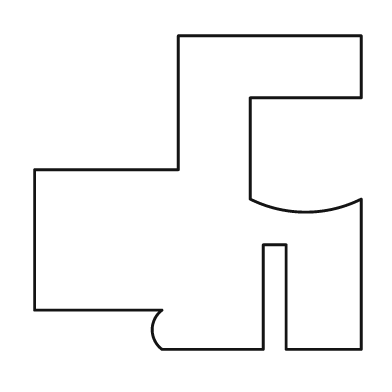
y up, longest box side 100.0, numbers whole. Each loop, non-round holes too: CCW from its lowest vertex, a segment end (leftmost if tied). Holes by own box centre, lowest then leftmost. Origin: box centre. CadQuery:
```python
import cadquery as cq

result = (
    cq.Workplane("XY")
    .moveTo(-11.0, -48.0)
    .lineTo(20.0, -48.0)
    .lineTo(20.0, -16.0)
    .lineTo(27.0, -16.0)
    .lineTo(27.0, -48.0)
    .lineTo(50.0, -48.0)
    .lineTo(50.0, -2.0)
    .threePointArc((33.0, -6.0), (16.0, -2.0))
    .lineTo(16.0, 29.0)
    .lineTo(50.0, 29.0)
    .lineTo(50.0, 48.0)
    .lineTo(-6.0, 48.0)
    .lineTo(-6.0, 7.0)
    .lineTo(-50.0, 7.0)
    .lineTo(-50.0, -36.0)
    .lineTo(-11.0, -36.0)
    .threePointArc((-14.0, -42.0), (-11.0, -48.0))
    .close()
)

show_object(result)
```